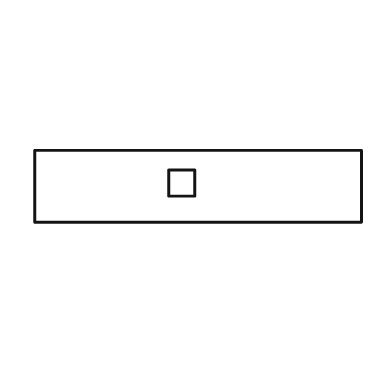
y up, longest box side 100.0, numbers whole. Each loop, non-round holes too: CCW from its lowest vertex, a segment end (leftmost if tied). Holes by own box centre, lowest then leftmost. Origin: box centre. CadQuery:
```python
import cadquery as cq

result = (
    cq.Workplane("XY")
    .moveTo(-50.0, -11.0)
    .lineTo(50.0, -11.0)
    .lineTo(50.0, 11.0)
    .lineTo(-50.0, 11.0)
    .close()
    .moveTo(-9.0, -3.0)
    .lineTo(-1.0, -3.0)
    .lineTo(-1.0, 5.0)
    .lineTo(-9.0, 5.0)
    .close()
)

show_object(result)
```